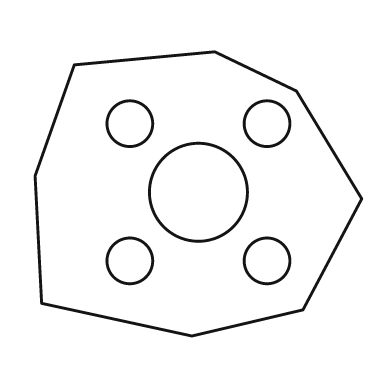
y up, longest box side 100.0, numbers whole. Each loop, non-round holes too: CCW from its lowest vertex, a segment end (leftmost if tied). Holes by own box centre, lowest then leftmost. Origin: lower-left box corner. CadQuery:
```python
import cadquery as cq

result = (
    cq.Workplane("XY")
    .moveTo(48.0, 0.0)
    .lineTo(82.0, 8.0)
    .lineTo(100.0, 42.0)
    .lineTo(80.0, 75.0)
    .lineTo(55.0, 87.0)
    .lineTo(12.0, 83.0)
    .lineTo(0.0, 49.0)
    .lineTo(2.0, 10.0)
    .close()
    .moveTo(29.0, 23.0)
    .circle(7.0)
    .moveTo(71.0, 23.0)
    .circle(7.0)
    .moveTo(50.0, 44.0)
    .circle(15.0)
    .moveTo(29.0, 65.0)
    .circle(7.0)
    .moveTo(71.0, 65.0)
    .circle(7.0)
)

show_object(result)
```